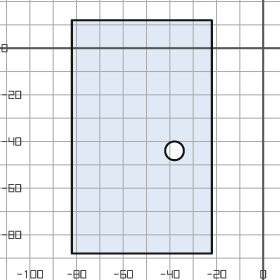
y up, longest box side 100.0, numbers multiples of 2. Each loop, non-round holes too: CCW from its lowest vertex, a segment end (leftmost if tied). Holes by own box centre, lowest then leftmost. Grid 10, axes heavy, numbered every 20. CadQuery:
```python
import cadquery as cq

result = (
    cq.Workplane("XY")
    .moveTo(-82.0, -88.0)
    .lineTo(-22.0, -88.0)
    .lineTo(-22.0, 12.0)
    .lineTo(-82.0, 12.0)
    .close()
    .moveTo(-38.0, -44.0)
    .circle(4.0)
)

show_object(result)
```